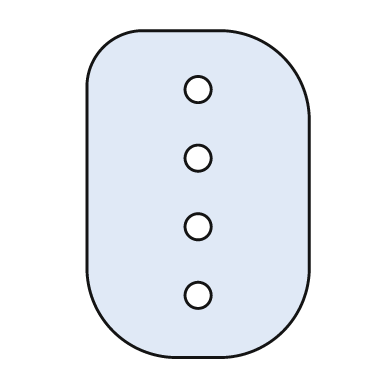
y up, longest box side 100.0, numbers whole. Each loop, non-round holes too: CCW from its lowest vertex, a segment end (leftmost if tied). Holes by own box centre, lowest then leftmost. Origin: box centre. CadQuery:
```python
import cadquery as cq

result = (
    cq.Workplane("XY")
    .moveTo(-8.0, -50.0)
    .lineTo(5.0, -50.0)
    .threePointArc((26.0, -42.0), (34.0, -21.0))
    .lineTo(34.0, 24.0)
    .threePointArc((26.0, 42.0), (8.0, 50.0))
    .lineTo(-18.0, 50.0)
    .threePointArc((-29.0, 45.0), (-34.0, 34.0))
    .lineTo(-34.0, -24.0)
    .threePointArc((-26.0, -42.0), (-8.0, -50.0))
    .close()
    .moveTo(0.0, -31.0)
    .circle(4.0)
    .moveTo(0.0, -10.0)
    .circle(4.0)
    .moveTo(0.0, 11.0)
    .circle(4.0)
    .moveTo(0.0, 32.0)
    .circle(4.0)
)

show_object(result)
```